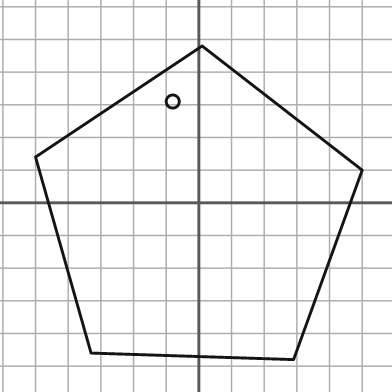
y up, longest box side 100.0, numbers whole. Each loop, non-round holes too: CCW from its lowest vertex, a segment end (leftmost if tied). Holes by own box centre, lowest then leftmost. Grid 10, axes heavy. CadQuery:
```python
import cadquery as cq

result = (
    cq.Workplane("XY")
    .moveTo(29.0, -48.0)
    .lineTo(50.0, 10.0)
    .lineTo(1.0, 48.0)
    .lineTo(-50.0, 14.0)
    .lineTo(-33.0, -46.0)
    .close()
    .moveTo(-8.0, 31.0)
    .circle(2.0)
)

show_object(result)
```